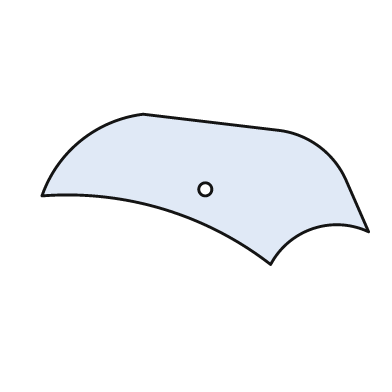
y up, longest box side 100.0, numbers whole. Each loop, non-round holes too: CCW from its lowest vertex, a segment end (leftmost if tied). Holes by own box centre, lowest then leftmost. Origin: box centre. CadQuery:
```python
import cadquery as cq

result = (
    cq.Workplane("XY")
    .moveTo(20.0, -23.0)
    .threePointArc((33.0, -12.0), (50.0, -13.0))
    .lineTo(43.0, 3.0)
    .threePointArc((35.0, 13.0), (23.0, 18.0))
    .lineTo(-19.0, 23.0)
    .threePointArc((-38.0, 15.0), (-50.0, -2.0))
    .threePointArc((-13.0, -6.0), (20.0, -23.0))
    .close()
    .moveTo(0.0, 0.0)
    .circle(2.0)
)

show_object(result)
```